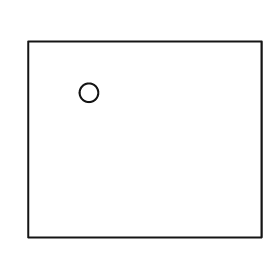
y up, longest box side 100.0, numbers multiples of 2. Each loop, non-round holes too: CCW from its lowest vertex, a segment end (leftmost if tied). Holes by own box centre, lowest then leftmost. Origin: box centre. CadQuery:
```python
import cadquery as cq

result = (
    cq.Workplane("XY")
    .moveTo(-50.0, -42.0)
    .lineTo(50.0, -42.0)
    .lineTo(50.0, 42.0)
    .lineTo(-50.0, 42.0)
    .close()
    .moveTo(-24.0, 20.0)
    .circle(4.0)
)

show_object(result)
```